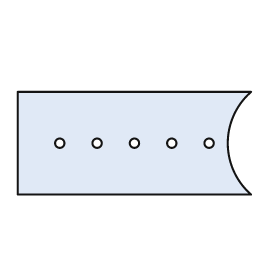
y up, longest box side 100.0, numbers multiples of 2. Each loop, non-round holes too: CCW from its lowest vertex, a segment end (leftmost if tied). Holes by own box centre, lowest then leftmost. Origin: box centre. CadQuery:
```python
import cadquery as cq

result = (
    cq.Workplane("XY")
    .moveTo(-50.0, -22.0)
    .lineTo(50.0, -22.0)
    .threePointArc((40.0, 0.0), (50.0, 22.0))
    .lineTo(-50.0, 22.0)
    .close()
    .moveTo(-32.0, 0.0)
    .circle(2.0)
    .moveTo(-16.0, 0.0)
    .circle(2.0)
    .moveTo(0.0, 0.0)
    .circle(2.0)
    .moveTo(16.0, 0.0)
    .circle(2.0)
    .moveTo(32.0, 0.0)
    .circle(2.0)
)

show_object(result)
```